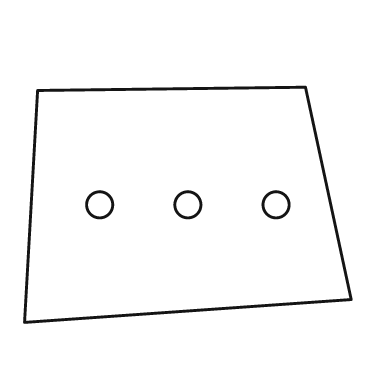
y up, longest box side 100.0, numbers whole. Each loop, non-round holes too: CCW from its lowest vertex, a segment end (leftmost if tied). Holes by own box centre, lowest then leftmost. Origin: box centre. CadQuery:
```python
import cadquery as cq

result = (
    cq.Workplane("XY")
    .moveTo(-50.0, -36.0)
    .lineTo(50.0, -29.0)
    .lineTo(36.0, 36.0)
    .lineTo(-46.0, 35.0)
    .close()
    .moveTo(-27.0, 0.0)
    .circle(4.0)
    .moveTo(0.0, 0.0)
    .circle(4.0)
    .moveTo(27.0, 0.0)
    .circle(4.0)
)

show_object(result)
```